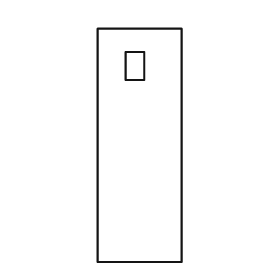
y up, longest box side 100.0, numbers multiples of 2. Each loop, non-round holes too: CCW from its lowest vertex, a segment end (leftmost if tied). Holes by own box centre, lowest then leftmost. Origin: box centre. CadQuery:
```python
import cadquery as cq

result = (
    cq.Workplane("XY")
    .moveTo(-18.0, -50.0)
    .lineTo(18.0, -50.0)
    .lineTo(18.0, 50.0)
    .lineTo(-18.0, 50.0)
    .close()
    .moveTo(-6.0, 28.0)
    .lineTo(2.0, 28.0)
    .lineTo(2.0, 40.0)
    .lineTo(-6.0, 40.0)
    .close()
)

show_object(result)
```